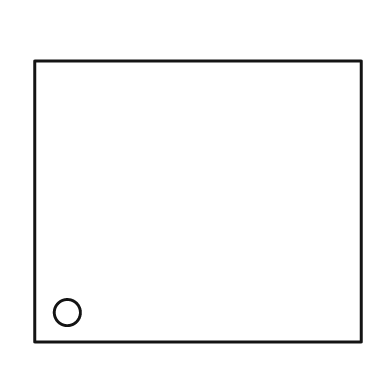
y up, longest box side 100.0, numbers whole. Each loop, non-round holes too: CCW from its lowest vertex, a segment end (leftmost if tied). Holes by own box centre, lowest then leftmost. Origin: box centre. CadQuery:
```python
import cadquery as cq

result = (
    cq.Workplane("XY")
    .moveTo(-50.0, -43.0)
    .lineTo(50.0, -43.0)
    .lineTo(50.0, 43.0)
    .lineTo(-50.0, 43.0)
    .close()
    .moveTo(-40.0, -34.0)
    .circle(4.0)
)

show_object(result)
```